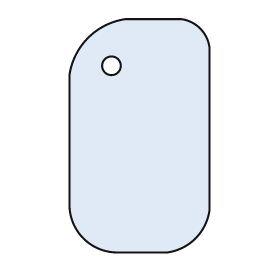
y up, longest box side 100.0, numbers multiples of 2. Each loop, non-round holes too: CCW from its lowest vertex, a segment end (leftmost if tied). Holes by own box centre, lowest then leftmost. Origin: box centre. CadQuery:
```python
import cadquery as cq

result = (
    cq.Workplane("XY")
    .moveTo(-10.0, -50.0)
    .lineTo(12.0, -50.0)
    .threePointArc((24.0, -44.0), (30.0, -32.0))
    .lineTo(30.0, 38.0)
    .threePointArc((26.0, 46.0), (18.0, 50.0))
    .lineTo(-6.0, 50.0)
    .threePointArc((-22.0, 42.0), (-30.0, 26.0))
    .lineTo(-30.0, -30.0)
    .threePointArc((-24.0, -44.0), (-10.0, -50.0))
    .close()
    .moveTo(-12.0, 30.0)
    .circle(4.0)
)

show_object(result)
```